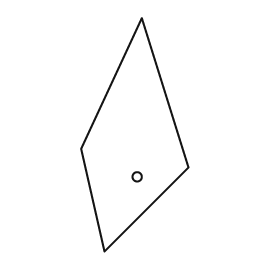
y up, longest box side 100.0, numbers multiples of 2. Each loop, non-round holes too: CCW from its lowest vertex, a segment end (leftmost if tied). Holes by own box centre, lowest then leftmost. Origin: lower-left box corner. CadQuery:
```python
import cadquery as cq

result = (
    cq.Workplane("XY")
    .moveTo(10.0, 0.0)
    .lineTo(46.0, 36.0)
    .lineTo(26.0, 100.0)
    .lineTo(0.0, 44.0)
    .close()
    .moveTo(24.0, 32.0)
    .circle(2.0)
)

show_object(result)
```